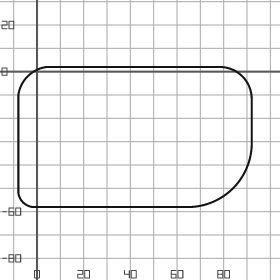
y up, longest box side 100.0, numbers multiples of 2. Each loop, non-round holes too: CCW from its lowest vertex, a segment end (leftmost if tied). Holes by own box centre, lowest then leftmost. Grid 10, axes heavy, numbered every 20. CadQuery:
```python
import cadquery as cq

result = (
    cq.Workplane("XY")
    .moveTo(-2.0, -58.0)
    .lineTo(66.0, -58.0)
    .threePointArc((84.0, -50.0), (92.0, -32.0))
    .lineTo(92.0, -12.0)
    .threePointArc((88.0, -2.0), (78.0, 2.0))
    .lineTo(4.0, 2.0)
    .threePointArc((-4.0, -2.0), (-8.0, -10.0))
    .lineTo(-8.0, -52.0)
    .threePointArc((-6.0, -56.0), (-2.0, -58.0))
    .close()
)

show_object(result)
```